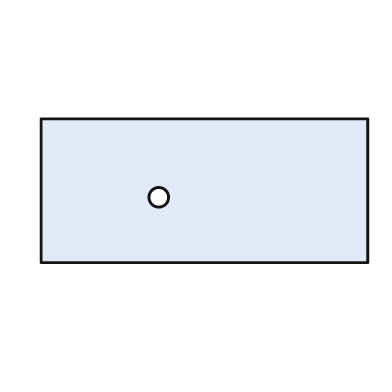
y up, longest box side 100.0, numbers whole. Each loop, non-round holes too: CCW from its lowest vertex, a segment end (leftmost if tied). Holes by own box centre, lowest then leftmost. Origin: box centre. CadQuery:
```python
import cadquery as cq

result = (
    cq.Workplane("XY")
    .moveTo(-50.0, -22.0)
    .lineTo(50.0, -22.0)
    .lineTo(50.0, 22.0)
    .lineTo(-50.0, 22.0)
    .close()
    .moveTo(-14.0, -2.0)
    .circle(3.0)
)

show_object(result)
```